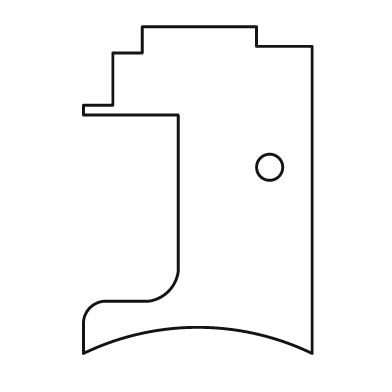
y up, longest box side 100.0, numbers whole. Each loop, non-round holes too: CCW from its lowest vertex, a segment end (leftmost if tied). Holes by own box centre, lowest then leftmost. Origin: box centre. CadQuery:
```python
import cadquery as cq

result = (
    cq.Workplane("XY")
    .moveTo(-35.0, -50.0)
    .threePointArc((0.0, -42.0), (35.0, -50.0))
    .lineTo(35.0, 44.0)
    .lineTo(18.0, 44.0)
    .lineTo(18.0, 50.0)
    .lineTo(-17.0, 50.0)
    .lineTo(-17.0, 42.0)
    .lineTo(-26.0, 42.0)
    .lineTo(-26.0, 26.0)
    .lineTo(-35.0, 26.0)
    .lineTo(-35.0, 23.0)
    .lineTo(-6.0, 23.0)
    .lineTo(-6.0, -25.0)
    .threePointArc((-9.0, -31.0), (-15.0, -34.0))
    .lineTo(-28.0, -34.0)
    .threePointArc((-33.0, -36.0), (-35.0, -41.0))
    .close()
    .moveTo(22.0, 7.0)
    .circle(4.0)
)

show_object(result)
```